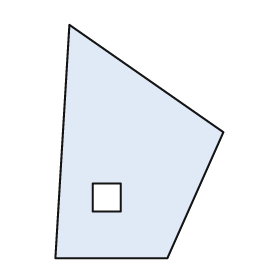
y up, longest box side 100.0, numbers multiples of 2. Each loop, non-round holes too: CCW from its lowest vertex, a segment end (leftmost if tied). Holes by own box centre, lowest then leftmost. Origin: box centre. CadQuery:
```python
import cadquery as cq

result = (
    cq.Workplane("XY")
    .moveTo(-36.0, -50.0)
    .lineTo(12.0, -50.0)
    .lineTo(36.0, 4.0)
    .lineTo(-30.0, 50.0)
    .close()
    .moveTo(-20.0, -30.0)
    .lineTo(-8.0, -30.0)
    .lineTo(-8.0, -18.0)
    .lineTo(-20.0, -18.0)
    .close()
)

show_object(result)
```